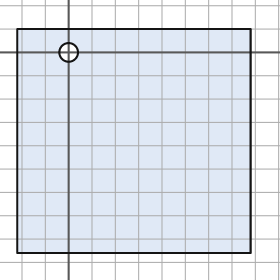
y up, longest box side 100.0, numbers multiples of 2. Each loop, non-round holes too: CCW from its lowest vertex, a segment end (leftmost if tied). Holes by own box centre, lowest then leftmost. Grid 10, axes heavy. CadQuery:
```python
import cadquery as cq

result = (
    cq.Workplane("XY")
    .moveTo(-22.0, -86.0)
    .lineTo(78.0, -86.0)
    .lineTo(78.0, 10.0)
    .lineTo(-22.0, 10.0)
    .close()
    .moveTo(0.0, 0.0)
    .circle(4.0)
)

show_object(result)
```